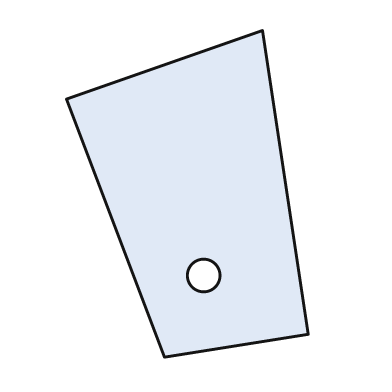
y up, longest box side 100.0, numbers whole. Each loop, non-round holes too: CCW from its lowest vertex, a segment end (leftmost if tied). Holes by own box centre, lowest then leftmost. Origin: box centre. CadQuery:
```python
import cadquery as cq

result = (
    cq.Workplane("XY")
    .moveTo(-7.0, -50.0)
    .lineTo(37.0, -43.0)
    .lineTo(23.0, 50.0)
    .lineTo(-37.0, 29.0)
    .close()
    .moveTo(5.0, -25.0)
    .circle(5.0)
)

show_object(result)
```